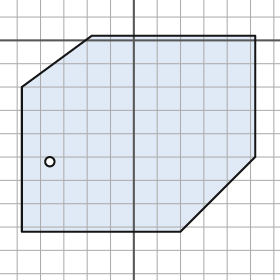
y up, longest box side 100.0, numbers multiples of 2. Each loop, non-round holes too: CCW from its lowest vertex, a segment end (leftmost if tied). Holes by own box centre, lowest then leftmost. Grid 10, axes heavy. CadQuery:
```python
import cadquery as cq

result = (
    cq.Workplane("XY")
    .moveTo(-48.0, -82.0)
    .lineTo(20.0, -82.0)
    .lineTo(52.0, -50.0)
    .lineTo(52.0, 2.0)
    .lineTo(-18.0, 2.0)
    .lineTo(-48.0, -20.0)
    .close()
    .moveTo(-36.0, -52.0)
    .circle(2.0)
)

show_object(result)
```